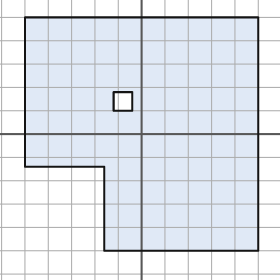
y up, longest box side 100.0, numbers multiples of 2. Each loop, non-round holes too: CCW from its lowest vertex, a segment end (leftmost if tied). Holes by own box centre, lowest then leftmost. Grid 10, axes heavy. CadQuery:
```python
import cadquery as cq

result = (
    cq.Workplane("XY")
    .moveTo(-16.0, -50.0)
    .lineTo(50.0, -50.0)
    .lineTo(50.0, 50.0)
    .lineTo(-50.0, 50.0)
    .lineTo(-50.0, -14.0)
    .lineTo(-16.0, -14.0)
    .close()
    .moveTo(-12.0, 10.0)
    .lineTo(-4.0, 10.0)
    .lineTo(-4.0, 18.0)
    .lineTo(-12.0, 18.0)
    .close()
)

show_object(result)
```